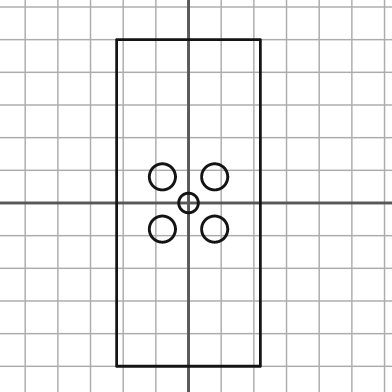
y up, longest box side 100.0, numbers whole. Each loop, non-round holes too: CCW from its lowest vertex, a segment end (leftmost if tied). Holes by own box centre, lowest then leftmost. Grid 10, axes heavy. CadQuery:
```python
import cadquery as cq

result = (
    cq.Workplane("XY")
    .moveTo(-22.0, -50.0)
    .lineTo(22.0, -50.0)
    .lineTo(22.0, 50.0)
    .lineTo(-22.0, 50.0)
    .close()
    .moveTo(-8.0, -8.0)
    .circle(4.0)
    .moveTo(8.0, -8.0)
    .circle(4.0)
    .moveTo(0.0, 0.0)
    .circle(3.0)
    .moveTo(-8.0, 8.0)
    .circle(4.0)
    .moveTo(8.0, 8.0)
    .circle(4.0)
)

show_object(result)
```